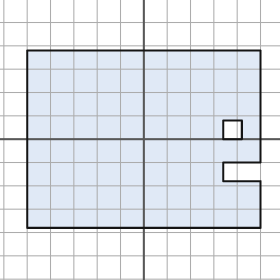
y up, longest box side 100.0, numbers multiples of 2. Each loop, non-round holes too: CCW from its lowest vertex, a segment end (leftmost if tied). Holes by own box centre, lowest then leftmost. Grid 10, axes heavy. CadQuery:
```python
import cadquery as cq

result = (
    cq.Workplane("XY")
    .moveTo(-50.0, -38.0)
    .lineTo(50.0, -38.0)
    .lineTo(50.0, -18.0)
    .lineTo(34.0, -18.0)
    .lineTo(34.0, -10.0)
    .lineTo(50.0, -10.0)
    .lineTo(50.0, 38.0)
    .lineTo(-50.0, 38.0)
    .close()
    .moveTo(34.0, 0.0)
    .lineTo(42.0, 0.0)
    .lineTo(42.0, 8.0)
    .lineTo(34.0, 8.0)
    .close()
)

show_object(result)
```